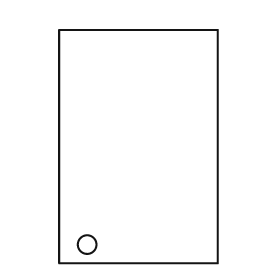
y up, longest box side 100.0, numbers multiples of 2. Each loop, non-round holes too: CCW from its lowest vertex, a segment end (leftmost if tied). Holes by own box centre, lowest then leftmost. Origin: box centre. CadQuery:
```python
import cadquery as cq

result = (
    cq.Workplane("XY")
    .moveTo(-34.0, -50.0)
    .lineTo(34.0, -50.0)
    .lineTo(34.0, 50.0)
    .lineTo(-34.0, 50.0)
    .close()
    .moveTo(-22.0, -42.0)
    .circle(4.0)
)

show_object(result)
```